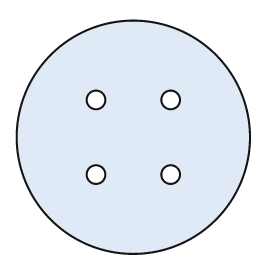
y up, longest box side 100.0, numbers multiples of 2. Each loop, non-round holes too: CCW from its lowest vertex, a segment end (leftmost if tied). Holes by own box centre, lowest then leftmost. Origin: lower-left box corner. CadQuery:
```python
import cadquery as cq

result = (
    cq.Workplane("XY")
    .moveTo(50.0, 50.0)
    .circle(50.0)
    .moveTo(34.0, 34.0)
    .circle(4.0)
    .moveTo(66.0, 34.0)
    .circle(4.0)
    .moveTo(34.0, 66.0)
    .circle(4.0)
    .moveTo(66.0, 66.0)
    .circle(4.0)
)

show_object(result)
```